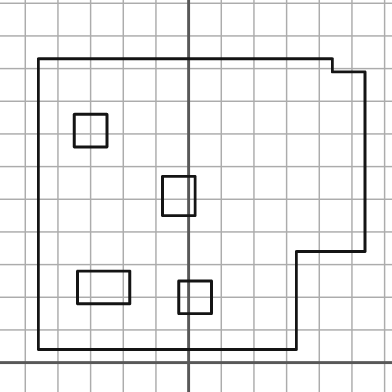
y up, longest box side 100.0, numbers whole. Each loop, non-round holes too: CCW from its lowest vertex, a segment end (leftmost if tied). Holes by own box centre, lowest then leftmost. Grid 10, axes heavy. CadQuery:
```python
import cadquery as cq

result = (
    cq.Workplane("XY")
    .moveTo(-46.0, 4.0)
    .lineTo(33.0, 4.0)
    .lineTo(33.0, 34.0)
    .lineTo(54.0, 34.0)
    .lineTo(54.0, 89.0)
    .lineTo(44.0, 89.0)
    .lineTo(44.0, 93.0)
    .lineTo(-46.0, 93.0)
    .close()
    .moveTo(-3.0, 15.0)
    .lineTo(7.0, 15.0)
    .lineTo(7.0, 25.0)
    .lineTo(-3.0, 25.0)
    .close()
    .moveTo(-34.0, 18.0)
    .lineTo(-18.0, 18.0)
    .lineTo(-18.0, 28.0)
    .lineTo(-34.0, 28.0)
    .close()
    .moveTo(-8.0, 45.0)
    .lineTo(2.0, 45.0)
    .lineTo(2.0, 57.0)
    .lineTo(-8.0, 57.0)
    .close()
    .moveTo(-35.0, 66.0)
    .lineTo(-25.0, 66.0)
    .lineTo(-25.0, 76.0)
    .lineTo(-35.0, 76.0)
    .close()
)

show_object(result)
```